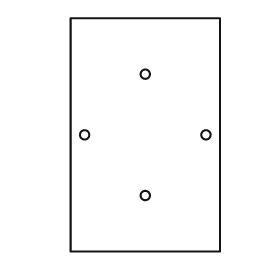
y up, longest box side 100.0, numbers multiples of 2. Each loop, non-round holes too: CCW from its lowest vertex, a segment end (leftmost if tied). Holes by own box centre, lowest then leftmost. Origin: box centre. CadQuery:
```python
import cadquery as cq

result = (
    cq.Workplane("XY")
    .moveTo(-32.0, -50.0)
    .lineTo(32.0, -50.0)
    .lineTo(32.0, 50.0)
    .lineTo(-32.0, 50.0)
    .close()
    .moveTo(0.0, -26.0)
    .circle(2.0)
    .moveTo(-26.0, 0.0)
    .circle(2.0)
    .moveTo(26.0, 0.0)
    .circle(2.0)
    .moveTo(0.0, 26.0)
    .circle(2.0)
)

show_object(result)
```